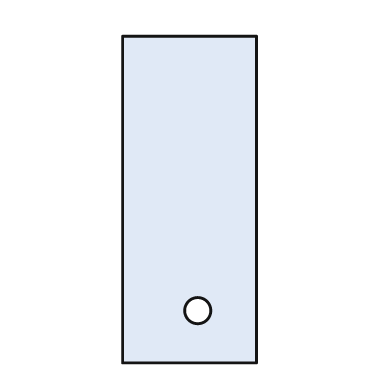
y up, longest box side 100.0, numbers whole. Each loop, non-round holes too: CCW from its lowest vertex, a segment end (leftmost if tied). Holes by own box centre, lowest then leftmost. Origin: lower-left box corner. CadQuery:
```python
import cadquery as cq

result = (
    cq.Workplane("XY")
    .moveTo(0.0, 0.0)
    .lineTo(41.0, 0.0)
    .lineTo(41.0, 100.0)
    .lineTo(0.0, 100.0)
    .close()
    .moveTo(23.0, 16.0)
    .circle(4.0)
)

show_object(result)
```